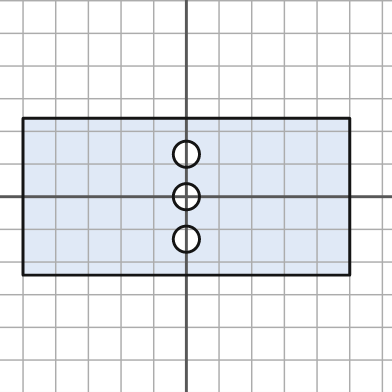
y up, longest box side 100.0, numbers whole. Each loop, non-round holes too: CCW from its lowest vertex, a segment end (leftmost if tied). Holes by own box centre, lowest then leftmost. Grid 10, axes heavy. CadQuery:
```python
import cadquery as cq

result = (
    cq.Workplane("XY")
    .moveTo(-50.0, -24.0)
    .lineTo(50.0, -24.0)
    .lineTo(50.0, 24.0)
    .lineTo(-50.0, 24.0)
    .close()
    .moveTo(0.0, -13.0)
    .circle(4.0)
    .moveTo(0.0, 0.0)
    .circle(4.0)
    .moveTo(0.0, 13.0)
    .circle(4.0)
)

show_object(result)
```